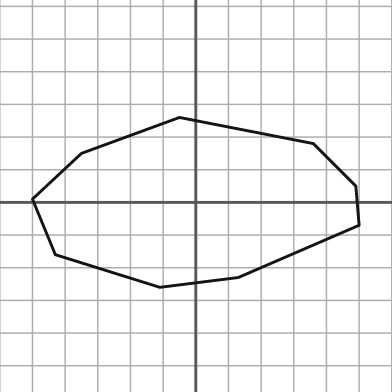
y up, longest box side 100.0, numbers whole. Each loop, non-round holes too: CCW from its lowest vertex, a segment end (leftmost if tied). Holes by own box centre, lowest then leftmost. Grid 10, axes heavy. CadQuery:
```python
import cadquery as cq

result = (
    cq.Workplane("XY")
    .moveTo(-11.0, -26.0)
    .lineTo(13.0, -23.0)
    .lineTo(50.0, -7.0)
    .lineTo(49.0, 5.0)
    .lineTo(36.0, 18.0)
    .lineTo(-5.0, 26.0)
    .lineTo(-35.0, 15.0)
    .lineTo(-50.0, 1.0)
    .lineTo(-43.0, -16.0)
    .close()
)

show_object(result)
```